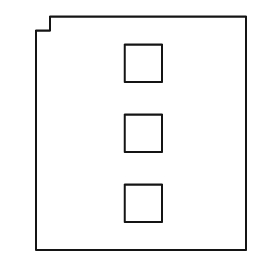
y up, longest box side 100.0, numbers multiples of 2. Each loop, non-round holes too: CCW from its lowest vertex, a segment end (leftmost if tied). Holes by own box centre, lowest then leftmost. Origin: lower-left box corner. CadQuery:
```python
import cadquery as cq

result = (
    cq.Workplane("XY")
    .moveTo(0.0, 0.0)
    .lineTo(90.0, 0.0)
    .lineTo(90.0, 100.0)
    .lineTo(6.0, 100.0)
    .lineTo(6.0, 94.0)
    .lineTo(0.0, 94.0)
    .close()
    .moveTo(38.0, 12.0)
    .lineTo(54.0, 12.0)
    .lineTo(54.0, 28.0)
    .lineTo(38.0, 28.0)
    .close()
    .moveTo(38.0, 42.0)
    .lineTo(54.0, 42.0)
    .lineTo(54.0, 58.0)
    .lineTo(38.0, 58.0)
    .close()
    .moveTo(38.0, 72.0)
    .lineTo(54.0, 72.0)
    .lineTo(54.0, 88.0)
    .lineTo(38.0, 88.0)
    .close()
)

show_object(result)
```